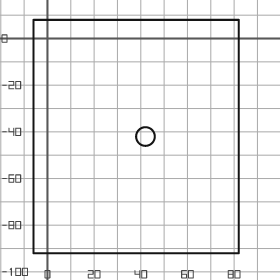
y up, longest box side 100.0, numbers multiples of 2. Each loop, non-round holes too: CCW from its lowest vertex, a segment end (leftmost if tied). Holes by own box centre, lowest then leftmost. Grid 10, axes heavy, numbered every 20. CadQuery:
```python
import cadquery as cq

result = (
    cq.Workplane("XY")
    .moveTo(-6.0, -92.0)
    .lineTo(82.0, -92.0)
    .lineTo(82.0, 8.0)
    .lineTo(-6.0, 8.0)
    .close()
    .moveTo(42.0, -42.0)
    .circle(4.0)
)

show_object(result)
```